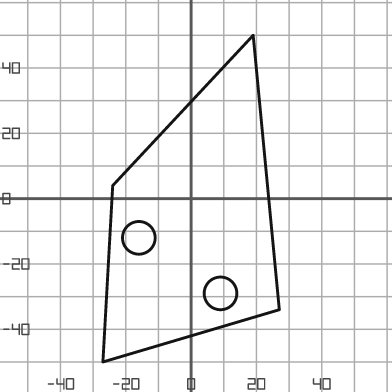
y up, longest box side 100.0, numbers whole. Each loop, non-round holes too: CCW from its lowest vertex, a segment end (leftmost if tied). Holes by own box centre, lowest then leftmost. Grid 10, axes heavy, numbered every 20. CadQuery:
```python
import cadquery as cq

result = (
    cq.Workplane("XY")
    .moveTo(-27.0, -50.0)
    .lineTo(27.0, -34.0)
    .lineTo(19.0, 50.0)
    .lineTo(-24.0, 4.0)
    .close()
    .moveTo(9.0, -29.0)
    .circle(5.0)
    .moveTo(-16.0, -12.0)
    .circle(5.0)
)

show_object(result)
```